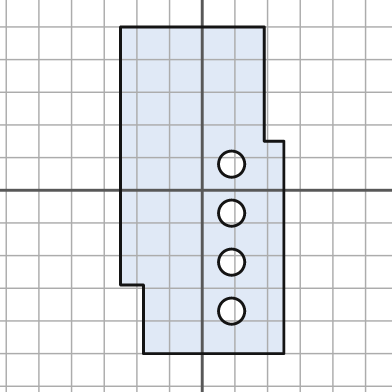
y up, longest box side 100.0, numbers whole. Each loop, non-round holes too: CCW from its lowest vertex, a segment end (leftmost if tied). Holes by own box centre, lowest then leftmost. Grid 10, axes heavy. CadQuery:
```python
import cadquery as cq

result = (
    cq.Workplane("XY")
    .moveTo(-18.0, -50.0)
    .lineTo(25.0, -50.0)
    .lineTo(25.0, 15.0)
    .lineTo(19.0, 15.0)
    .lineTo(19.0, 50.0)
    .lineTo(-25.0, 50.0)
    .lineTo(-25.0, -29.0)
    .lineTo(-18.0, -29.0)
    .close()
    .moveTo(9.0, -37.0)
    .circle(4.0)
    .moveTo(9.0, -22.0)
    .circle(4.0)
    .moveTo(9.0, -7.0)
    .circle(4.0)
    .moveTo(9.0, 8.0)
    .circle(4.0)
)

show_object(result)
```